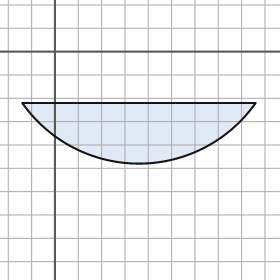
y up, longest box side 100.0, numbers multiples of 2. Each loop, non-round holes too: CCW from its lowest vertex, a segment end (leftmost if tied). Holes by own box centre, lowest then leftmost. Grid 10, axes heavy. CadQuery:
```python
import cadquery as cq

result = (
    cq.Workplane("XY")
    .moveTo(-14.0, -22.0)
    .threePointArc((36.0, -48.0), (86.0, -22.0))
    .close()
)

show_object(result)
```